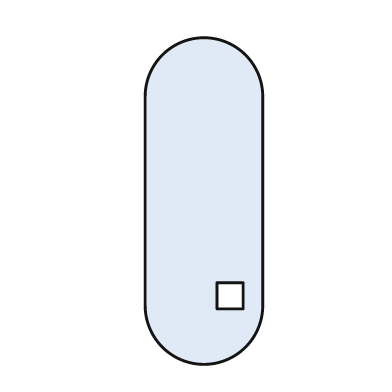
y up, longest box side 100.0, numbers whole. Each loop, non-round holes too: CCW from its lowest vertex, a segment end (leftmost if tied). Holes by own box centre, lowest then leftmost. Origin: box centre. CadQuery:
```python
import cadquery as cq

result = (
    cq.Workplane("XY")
    .moveTo(-18.0, -32.0)
    .threePointArc((0.0, -50.0), (18.0, -32.0))
    .lineTo(18.0, 32.0)
    .threePointArc((0.0, 50.0), (-18.0, 32.0))
    .close()
    .moveTo(4.0, -33.0)
    .lineTo(12.0, -33.0)
    .lineTo(12.0, -25.0)
    .lineTo(4.0, -25.0)
    .close()
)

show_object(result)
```